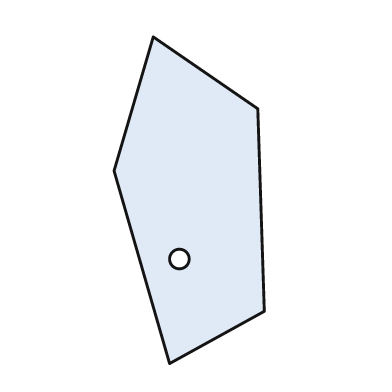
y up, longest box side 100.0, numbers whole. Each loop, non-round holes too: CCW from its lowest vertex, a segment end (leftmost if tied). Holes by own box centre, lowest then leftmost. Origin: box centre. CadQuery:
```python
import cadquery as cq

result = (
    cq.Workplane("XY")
    .moveTo(-6.0, -50.0)
    .lineTo(23.0, -34.0)
    .lineTo(21.0, 28.0)
    .lineTo(-11.0, 50.0)
    .lineTo(-23.0, 9.0)
    .close()
    .moveTo(-3.0, -18.0)
    .circle(3.0)
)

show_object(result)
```